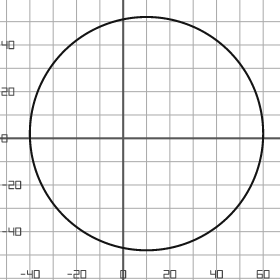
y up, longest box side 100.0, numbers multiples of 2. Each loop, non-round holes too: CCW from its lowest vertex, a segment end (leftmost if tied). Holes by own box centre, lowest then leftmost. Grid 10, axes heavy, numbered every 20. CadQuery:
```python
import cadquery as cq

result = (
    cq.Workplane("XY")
    .moveTo(10.0, 2.0)
    .circle(50.0)
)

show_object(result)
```